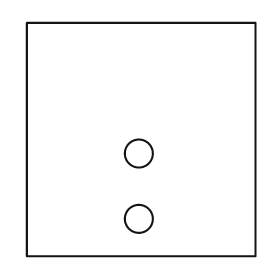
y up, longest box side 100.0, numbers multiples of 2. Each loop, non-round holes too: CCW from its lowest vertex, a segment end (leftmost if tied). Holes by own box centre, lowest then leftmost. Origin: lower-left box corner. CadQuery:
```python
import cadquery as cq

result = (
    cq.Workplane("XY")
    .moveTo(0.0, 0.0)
    .lineTo(98.0, 0.0)
    .lineTo(98.0, 100.0)
    .lineTo(0.0, 100.0)
    .close()
    .moveTo(48.0, 16.0)
    .circle(6.0)
    .moveTo(48.0, 44.0)
    .circle(6.0)
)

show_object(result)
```